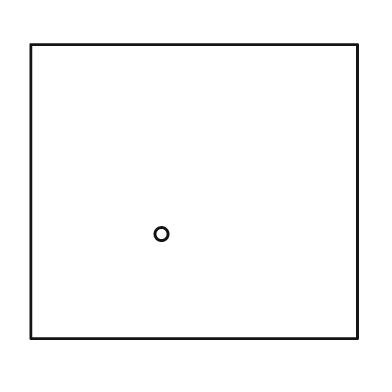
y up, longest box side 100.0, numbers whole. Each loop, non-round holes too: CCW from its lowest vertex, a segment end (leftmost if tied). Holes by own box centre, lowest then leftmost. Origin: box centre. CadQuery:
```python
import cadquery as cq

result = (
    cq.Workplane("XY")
    .moveTo(-50.0, -45.0)
    .lineTo(50.0, -45.0)
    .lineTo(50.0, 45.0)
    .lineTo(-50.0, 45.0)
    .close()
    .moveTo(-10.0, -13.0)
    .circle(2.0)
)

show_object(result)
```